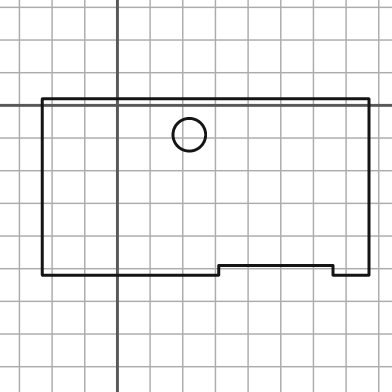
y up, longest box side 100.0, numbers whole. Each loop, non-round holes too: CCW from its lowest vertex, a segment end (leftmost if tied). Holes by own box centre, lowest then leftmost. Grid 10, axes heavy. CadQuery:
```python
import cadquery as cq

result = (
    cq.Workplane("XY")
    .moveTo(-23.0, -52.0)
    .lineTo(31.0, -52.0)
    .lineTo(31.0, -49.0)
    .lineTo(66.0, -49.0)
    .lineTo(66.0, -52.0)
    .lineTo(77.0, -52.0)
    .lineTo(77.0, 2.0)
    .lineTo(-23.0, 2.0)
    .close()
    .moveTo(22.0, -9.0)
    .circle(5.0)
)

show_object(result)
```